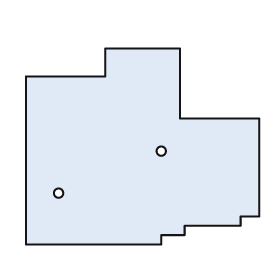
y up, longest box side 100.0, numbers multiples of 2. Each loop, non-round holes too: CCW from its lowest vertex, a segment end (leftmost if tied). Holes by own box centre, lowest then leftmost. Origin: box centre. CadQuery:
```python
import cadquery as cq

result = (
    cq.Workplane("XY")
    .moveTo(-50.0, -42.0)
    .lineTo(8.0, -42.0)
    .lineTo(8.0, -38.0)
    .lineTo(18.0, -38.0)
    .lineTo(18.0, -34.0)
    .lineTo(42.0, -34.0)
    .lineTo(42.0, -30.0)
    .lineTo(50.0, -30.0)
    .lineTo(50.0, 12.0)
    .lineTo(16.0, 12.0)
    .lineTo(16.0, 42.0)
    .lineTo(-16.0, 42.0)
    .lineTo(-16.0, 30.0)
    .lineTo(-50.0, 30.0)
    .close()
    .moveTo(-36.0, -20.0)
    .circle(2.0)
    .moveTo(8.0, -2.0)
    .circle(2.0)
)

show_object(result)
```